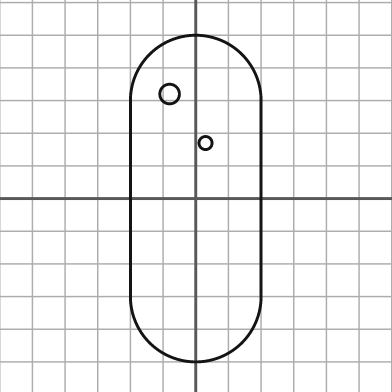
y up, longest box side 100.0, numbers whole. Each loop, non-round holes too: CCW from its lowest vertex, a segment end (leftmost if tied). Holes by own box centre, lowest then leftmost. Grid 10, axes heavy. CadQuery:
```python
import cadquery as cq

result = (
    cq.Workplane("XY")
    .moveTo(-20.0, -30.0)
    .threePointArc((0.0, -50.0), (20.0, -30.0))
    .lineTo(20.0, 30.0)
    .threePointArc((0.0, 50.0), (-20.0, 30.0))
    .close()
    .moveTo(3.0, 17.0)
    .circle(2.0)
    .moveTo(-8.0, 32.0)
    .circle(3.0)
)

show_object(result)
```